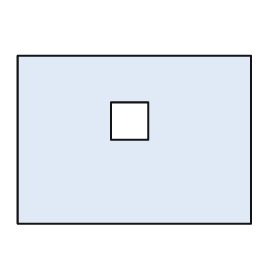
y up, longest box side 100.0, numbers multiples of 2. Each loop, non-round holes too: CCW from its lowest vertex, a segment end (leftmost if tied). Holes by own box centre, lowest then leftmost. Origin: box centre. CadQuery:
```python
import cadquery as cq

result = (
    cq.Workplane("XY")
    .moveTo(-50.0, -36.0)
    .lineTo(50.0, -36.0)
    .lineTo(50.0, 36.0)
    .lineTo(-50.0, 36.0)
    .close()
    .moveTo(-10.0, 0.0)
    .lineTo(6.0, 0.0)
    .lineTo(6.0, 16.0)
    .lineTo(-10.0, 16.0)
    .close()
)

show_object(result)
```